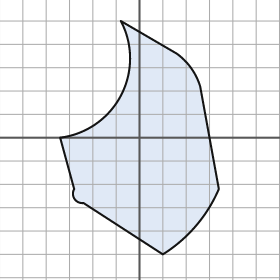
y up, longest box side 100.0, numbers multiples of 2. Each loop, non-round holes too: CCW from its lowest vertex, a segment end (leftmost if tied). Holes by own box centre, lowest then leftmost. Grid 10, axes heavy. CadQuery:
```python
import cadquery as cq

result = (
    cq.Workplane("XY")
    .moveTo(10.0, -50.0)
    .threePointArc((24.0, -38.0), (34.0, -22.0))
    .lineTo(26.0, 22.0)
    .threePointArc((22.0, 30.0), (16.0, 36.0))
    .lineTo(-8.0, 50.0)
    .threePointArc((-8.0, 18.0), (-34.0, 0.0))
    .lineTo(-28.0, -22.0)
    .threePointArc((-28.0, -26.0), (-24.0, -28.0))
    .close()
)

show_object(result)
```